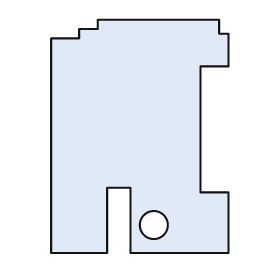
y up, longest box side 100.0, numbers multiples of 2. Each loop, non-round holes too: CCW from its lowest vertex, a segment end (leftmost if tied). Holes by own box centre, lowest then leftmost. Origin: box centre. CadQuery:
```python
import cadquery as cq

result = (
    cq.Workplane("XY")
    .moveTo(-38.0, -50.0)
    .lineTo(-14.0, -50.0)
    .lineTo(-14.0, -22.0)
    .lineTo(-4.0, -22.0)
    .lineTo(-4.0, -50.0)
    .lineTo(38.0, -50.0)
    .lineTo(38.0, -24.0)
    .lineTo(26.0, -24.0)
    .lineTo(26.0, 30.0)
    .lineTo(38.0, 30.0)
    .lineTo(38.0, 44.0)
    .lineTo(34.0, 44.0)
    .lineTo(34.0, 50.0)
    .lineTo(-18.0, 50.0)
    .lineTo(-18.0, 46.0)
    .lineTo(-26.0, 46.0)
    .lineTo(-26.0, 42.0)
    .lineTo(-38.0, 42.0)
    .close()
    .moveTo(6.0, -38.0)
    .circle(6.0)
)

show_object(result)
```